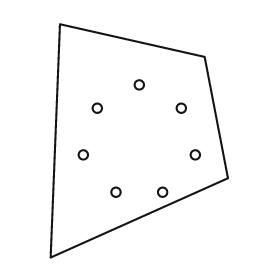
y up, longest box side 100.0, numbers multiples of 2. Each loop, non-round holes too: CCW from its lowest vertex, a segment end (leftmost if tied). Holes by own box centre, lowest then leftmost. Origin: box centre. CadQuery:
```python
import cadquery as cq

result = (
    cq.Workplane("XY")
    .moveTo(-38.0, -50.0)
    .lineTo(38.0, -16.0)
    .lineTo(28.0, 36.0)
    .lineTo(-34.0, 50.0)
    .close()
    .moveTo(-10.0, -22.0)
    .circle(2.0)
    .moveTo(10.0, -22.0)
    .circle(2.0)
    .moveTo(-24.0, -6.0)
    .circle(2.0)
    .moveTo(24.0, -6.0)
    .circle(2.0)
    .moveTo(-18.0, 14.0)
    .circle(2.0)
    .moveTo(18.0, 14.0)
    .circle(2.0)
    .moveTo(0.0, 24.0)
    .circle(2.0)
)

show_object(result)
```